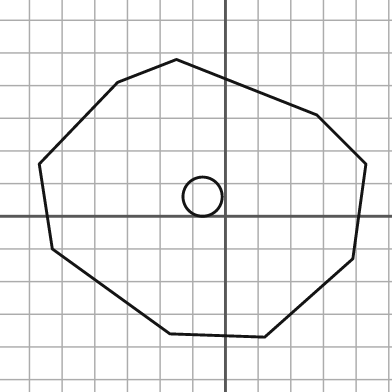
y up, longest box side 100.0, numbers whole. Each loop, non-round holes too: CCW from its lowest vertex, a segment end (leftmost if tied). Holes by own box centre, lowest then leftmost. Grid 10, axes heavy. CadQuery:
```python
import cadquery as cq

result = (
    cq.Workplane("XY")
    .moveTo(12.0, -37.0)
    .lineTo(39.0, -13.0)
    .lineTo(43.0, 16.0)
    .lineTo(28.0, 31.0)
    .lineTo(-15.0, 48.0)
    .lineTo(-33.0, 41.0)
    .lineTo(-57.0, 16.0)
    .lineTo(-53.0, -10.0)
    .lineTo(-17.0, -36.0)
    .close()
    .moveTo(-7.0, 6.0)
    .circle(6.0)
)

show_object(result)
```